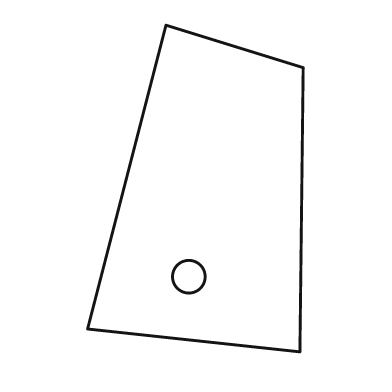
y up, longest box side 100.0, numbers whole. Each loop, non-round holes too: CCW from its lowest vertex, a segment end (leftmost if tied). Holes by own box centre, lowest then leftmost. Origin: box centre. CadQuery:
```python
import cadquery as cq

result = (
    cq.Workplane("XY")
    .moveTo(32.0, -50.0)
    .lineTo(33.0, 37.0)
    .lineTo(-9.0, 50.0)
    .lineTo(-33.0, -43.0)
    .close()
    .moveTo(-2.0, -27.0)
    .circle(5.0)
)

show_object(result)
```